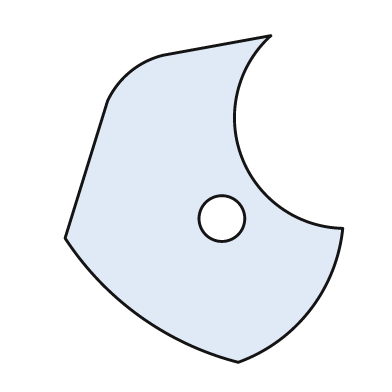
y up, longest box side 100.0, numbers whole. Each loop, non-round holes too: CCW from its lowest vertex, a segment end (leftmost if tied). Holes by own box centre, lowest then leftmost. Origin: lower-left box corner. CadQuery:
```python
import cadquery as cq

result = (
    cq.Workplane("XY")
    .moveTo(53.0, 0.0)
    .threePointArc((75.0, 16.0), (85.0, 41.0))
    .threePointArc((54.0, 63.0), (63.0, 100.0))
    .lineTo(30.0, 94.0)
    .threePointArc((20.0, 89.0), (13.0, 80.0))
    .lineTo(0.0, 38.0)
    .threePointArc((23.0, 14.0), (53.0, 0.0))
    .close()
    .moveTo(48.0, 44.0)
    .circle(7.0)
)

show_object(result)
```